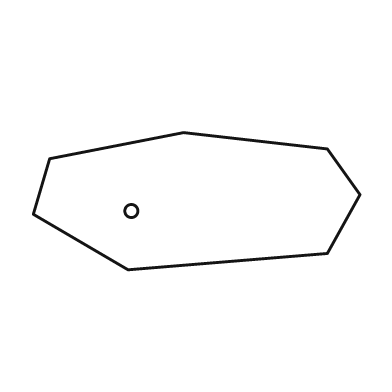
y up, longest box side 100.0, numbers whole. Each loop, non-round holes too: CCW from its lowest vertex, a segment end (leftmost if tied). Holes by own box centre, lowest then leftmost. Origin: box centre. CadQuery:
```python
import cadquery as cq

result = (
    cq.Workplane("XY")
    .moveTo(-21.0, -21.0)
    .lineTo(40.0, -16.0)
    .lineTo(50.0, 2.0)
    .lineTo(40.0, 16.0)
    .lineTo(-4.0, 21.0)
    .lineTo(-45.0, 13.0)
    .lineTo(-50.0, -4.0)
    .close()
    .moveTo(-20.0, -3.0)
    .circle(2.0)
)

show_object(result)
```